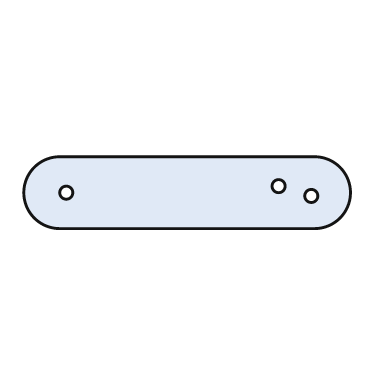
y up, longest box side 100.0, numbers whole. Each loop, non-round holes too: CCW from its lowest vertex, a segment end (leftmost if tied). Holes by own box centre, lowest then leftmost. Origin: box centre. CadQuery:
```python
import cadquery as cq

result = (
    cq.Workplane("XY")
    .moveTo(-39.0, -11.0)
    .lineTo(39.0, -11.0)
    .threePointArc((50.0, 0.0), (39.0, 11.0))
    .lineTo(-39.0, 11.0)
    .threePointArc((-50.0, 0.0), (-39.0, -11.0))
    .close()
    .moveTo(38.0, -1.0)
    .circle(2.0)
    .moveTo(-37.0, 0.0)
    .circle(2.0)
    .moveTo(28.0, 2.0)
    .circle(2.0)
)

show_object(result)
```